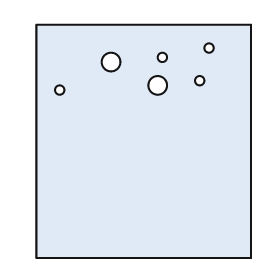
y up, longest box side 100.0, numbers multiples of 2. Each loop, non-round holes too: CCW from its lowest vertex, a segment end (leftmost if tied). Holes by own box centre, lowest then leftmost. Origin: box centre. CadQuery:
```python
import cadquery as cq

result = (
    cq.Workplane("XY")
    .moveTo(-46.0, -50.0)
    .lineTo(46.0, -50.0)
    .lineTo(46.0, 50.0)
    .lineTo(-46.0, 50.0)
    .close()
    .moveTo(-36.0, 22.0)
    .circle(2.0)
    .moveTo(6.0, 24.0)
    .circle(4.0)
    .moveTo(24.0, 26.0)
    .circle(2.0)
    .moveTo(-14.0, 34.0)
    .circle(4.0)
    .moveTo(8.0, 36.0)
    .circle(2.0)
    .moveTo(28.0, 40.0)
    .circle(2.0)
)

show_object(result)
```